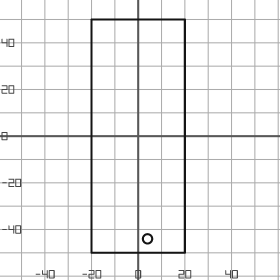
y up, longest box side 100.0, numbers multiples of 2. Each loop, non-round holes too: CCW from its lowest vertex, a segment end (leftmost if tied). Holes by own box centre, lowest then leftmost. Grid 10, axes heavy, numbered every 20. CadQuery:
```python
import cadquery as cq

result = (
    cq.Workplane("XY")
    .moveTo(-20.0, -50.0)
    .lineTo(20.0, -50.0)
    .lineTo(20.0, 50.0)
    .lineTo(-20.0, 50.0)
    .close()
    .moveTo(4.0, -44.0)
    .circle(2.0)
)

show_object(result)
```